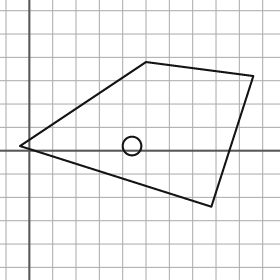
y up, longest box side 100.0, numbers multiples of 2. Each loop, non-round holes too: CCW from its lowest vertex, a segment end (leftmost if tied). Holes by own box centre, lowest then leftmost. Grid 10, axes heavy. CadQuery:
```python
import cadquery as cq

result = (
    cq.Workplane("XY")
    .moveTo(78.0, -24.0)
    .lineTo(96.0, 32.0)
    .lineTo(50.0, 38.0)
    .lineTo(-4.0, 2.0)
    .close()
    .moveTo(44.0, 2.0)
    .circle(4.0)
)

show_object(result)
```